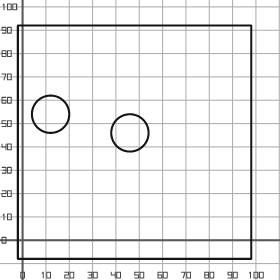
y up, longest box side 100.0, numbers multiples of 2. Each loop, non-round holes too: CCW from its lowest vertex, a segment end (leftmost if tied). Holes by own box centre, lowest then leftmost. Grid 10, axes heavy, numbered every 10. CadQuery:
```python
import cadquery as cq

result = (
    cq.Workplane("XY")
    .moveTo(-2.0, -8.0)
    .lineTo(98.0, -8.0)
    .lineTo(98.0, 92.0)
    .lineTo(-2.0, 92.0)
    .close()
    .moveTo(46.0, 46.0)
    .circle(8.0)
    .moveTo(12.0, 54.0)
    .circle(8.0)
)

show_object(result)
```